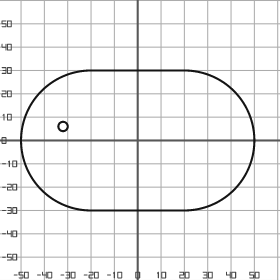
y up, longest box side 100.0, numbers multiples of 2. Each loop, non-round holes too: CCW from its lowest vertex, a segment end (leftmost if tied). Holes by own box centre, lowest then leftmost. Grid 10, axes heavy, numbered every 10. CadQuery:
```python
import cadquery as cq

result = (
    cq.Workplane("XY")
    .moveTo(-20.0, -30.0)
    .lineTo(20.0, -30.0)
    .threePointArc((50.0, 0.0), (20.0, 30.0))
    .lineTo(-20.0, 30.0)
    .threePointArc((-50.0, 0.0), (-20.0, -30.0))
    .close()
    .moveTo(-32.0, 6.0)
    .circle(2.0)
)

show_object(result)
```